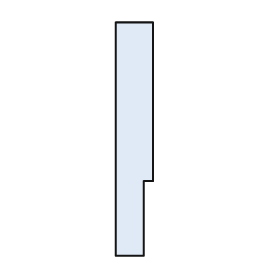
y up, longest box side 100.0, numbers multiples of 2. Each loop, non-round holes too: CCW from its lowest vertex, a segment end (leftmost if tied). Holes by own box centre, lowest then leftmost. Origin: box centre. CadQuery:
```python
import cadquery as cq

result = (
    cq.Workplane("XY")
    .moveTo(-8.0, -50.0)
    .lineTo(4.0, -50.0)
    .lineTo(4.0, -18.0)
    .lineTo(8.0, -18.0)
    .lineTo(8.0, 50.0)
    .lineTo(-8.0, 50.0)
    .close()
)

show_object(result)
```